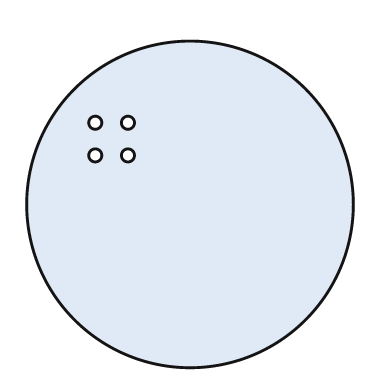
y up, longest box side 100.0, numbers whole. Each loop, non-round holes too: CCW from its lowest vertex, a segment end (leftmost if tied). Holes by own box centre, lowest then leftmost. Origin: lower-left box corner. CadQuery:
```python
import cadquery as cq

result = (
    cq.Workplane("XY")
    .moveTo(50.0, 50.0)
    .circle(50.0)
    .moveTo(21.0, 65.0)
    .circle(2.0)
    .moveTo(31.0, 65.0)
    .circle(2.0)
    .moveTo(21.0, 75.0)
    .circle(2.0)
    .moveTo(31.0, 75.0)
    .circle(2.0)
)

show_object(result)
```